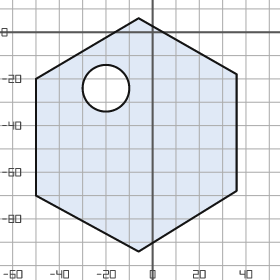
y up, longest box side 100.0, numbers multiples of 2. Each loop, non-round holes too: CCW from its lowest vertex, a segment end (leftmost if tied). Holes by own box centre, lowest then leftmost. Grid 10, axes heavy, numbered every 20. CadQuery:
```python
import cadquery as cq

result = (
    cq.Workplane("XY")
    .moveTo(-6.0, -94.0)
    .lineTo(36.0, -68.0)
    .lineTo(36.0, -18.0)
    .lineTo(-6.0, 6.0)
    .lineTo(-50.0, -20.0)
    .lineTo(-50.0, -70.0)
    .close()
    .moveTo(-20.0, -24.0)
    .circle(10.0)
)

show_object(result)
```